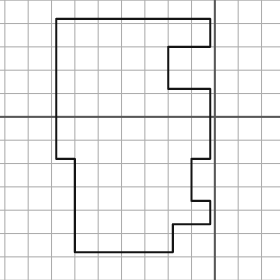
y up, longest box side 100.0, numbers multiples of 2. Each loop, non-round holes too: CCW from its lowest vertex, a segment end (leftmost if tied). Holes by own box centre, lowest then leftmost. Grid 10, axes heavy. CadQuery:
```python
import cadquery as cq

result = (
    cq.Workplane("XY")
    .moveTo(-60.0, -58.0)
    .lineTo(-18.0, -58.0)
    .lineTo(-18.0, -46.0)
    .lineTo(-2.0, -46.0)
    .lineTo(-2.0, -36.0)
    .lineTo(-10.0, -36.0)
    .lineTo(-10.0, -18.0)
    .lineTo(-2.0, -18.0)
    .lineTo(-2.0, 12.0)
    .lineTo(-20.0, 12.0)
    .lineTo(-20.0, 30.0)
    .lineTo(-2.0, 30.0)
    .lineTo(-2.0, 42.0)
    .lineTo(-68.0, 42.0)
    .lineTo(-68.0, -18.0)
    .lineTo(-60.0, -18.0)
    .close()
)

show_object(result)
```